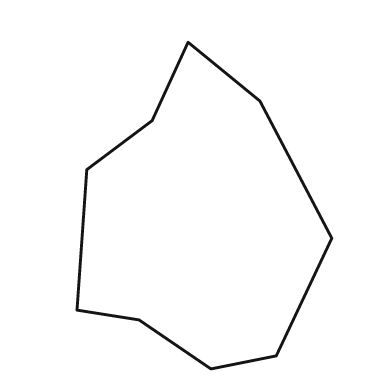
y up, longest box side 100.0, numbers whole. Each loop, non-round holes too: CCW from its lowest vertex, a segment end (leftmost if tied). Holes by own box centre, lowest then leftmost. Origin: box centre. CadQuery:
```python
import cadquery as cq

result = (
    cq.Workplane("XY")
    .moveTo(2.0, -50.0)
    .lineTo(22.0, -46.0)
    .lineTo(39.0, -10.0)
    .lineTo(17.0, 32.0)
    .lineTo(-5.0, 50.0)
    .lineTo(-16.0, 26.0)
    .lineTo(-36.0, 11.0)
    .lineTo(-39.0, -32.0)
    .lineTo(-20.0, -35.0)
    .close()
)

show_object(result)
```